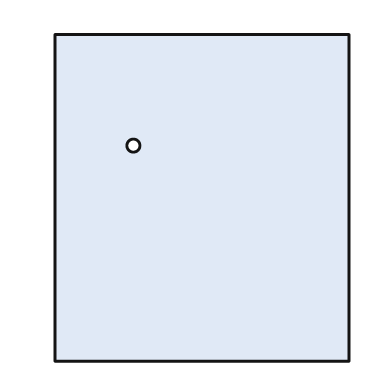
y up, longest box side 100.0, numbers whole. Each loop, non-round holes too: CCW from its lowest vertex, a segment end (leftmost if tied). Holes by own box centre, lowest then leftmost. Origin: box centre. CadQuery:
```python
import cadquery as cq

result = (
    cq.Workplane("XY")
    .moveTo(-45.0, -50.0)
    .lineTo(45.0, -50.0)
    .lineTo(45.0, 50.0)
    .lineTo(-45.0, 50.0)
    .close()
    .moveTo(-21.0, 16.0)
    .circle(2.0)
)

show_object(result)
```